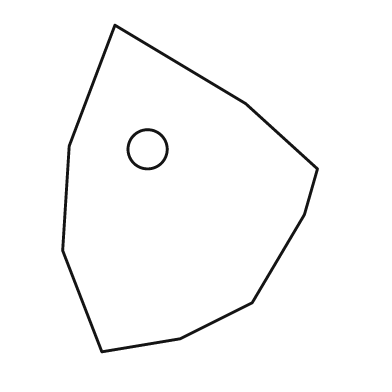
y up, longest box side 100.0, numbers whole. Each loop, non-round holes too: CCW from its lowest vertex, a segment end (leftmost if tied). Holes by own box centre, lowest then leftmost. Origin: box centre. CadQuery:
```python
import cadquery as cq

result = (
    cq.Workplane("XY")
    .moveTo(-27.0, -50.0)
    .lineTo(-3.0, -46.0)
    .lineTo(19.0, -35.0)
    .lineTo(35.0, -8.0)
    .lineTo(39.0, 6.0)
    .lineTo(17.0, 26.0)
    .lineTo(-23.0, 50.0)
    .lineTo(-37.0, 13.0)
    .lineTo(-39.0, -19.0)
    .close()
    .moveTo(-13.0, 12.0)
    .circle(6.0)
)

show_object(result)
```